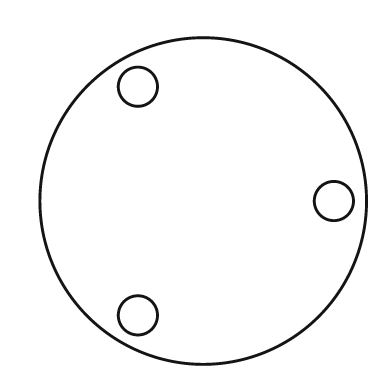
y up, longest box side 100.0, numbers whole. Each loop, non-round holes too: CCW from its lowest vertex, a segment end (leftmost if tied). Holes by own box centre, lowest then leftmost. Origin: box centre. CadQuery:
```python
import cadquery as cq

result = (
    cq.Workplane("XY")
    .moveTo(0.0, 0.0)
    .circle(50.0)
    .moveTo(-20.0, -35.0)
    .circle(6.0)
    .moveTo(40.0, 0.0)
    .circle(6.0)
    .moveTo(-20.0, 35.0)
    .circle(6.0)
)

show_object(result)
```